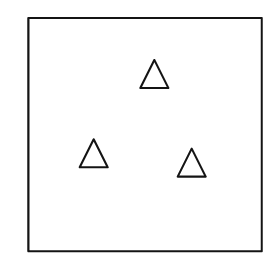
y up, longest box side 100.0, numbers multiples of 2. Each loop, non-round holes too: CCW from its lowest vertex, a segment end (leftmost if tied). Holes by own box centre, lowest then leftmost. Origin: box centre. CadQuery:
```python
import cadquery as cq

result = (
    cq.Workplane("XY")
    .moveTo(-50.0, -50.0)
    .lineTo(50.0, -50.0)
    .lineTo(50.0, 50.0)
    .lineTo(-50.0, 50.0)
    .close()
    .moveTo(14.0, -18.0)
    .lineTo(26.0, -18.0)
    .lineTo(20.0, -6.0)
    .close()
    .moveTo(-28.0, -14.0)
    .lineTo(-16.0, -14.0)
    .lineTo(-22.0, -2.0)
    .close()
    .moveTo(-2.0, 20.0)
    .lineTo(10.0, 20.0)
    .lineTo(4.0, 32.0)
    .close()
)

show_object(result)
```